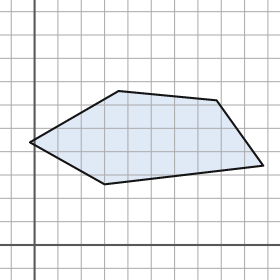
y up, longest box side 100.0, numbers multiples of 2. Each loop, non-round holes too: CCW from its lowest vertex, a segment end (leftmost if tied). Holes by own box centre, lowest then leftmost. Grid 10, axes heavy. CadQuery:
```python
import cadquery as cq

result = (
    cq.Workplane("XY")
    .moveTo(30.0, 26.0)
    .lineTo(98.0, 34.0)
    .lineTo(78.0, 62.0)
    .lineTo(36.0, 66.0)
    .lineTo(-2.0, 44.0)
    .close()
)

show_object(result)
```